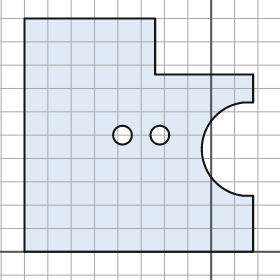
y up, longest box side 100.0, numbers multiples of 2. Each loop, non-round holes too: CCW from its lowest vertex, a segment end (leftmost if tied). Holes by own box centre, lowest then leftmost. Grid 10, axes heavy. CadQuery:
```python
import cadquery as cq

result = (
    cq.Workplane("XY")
    .moveTo(-80.0, 0.0)
    .lineTo(18.0, 0.0)
    .lineTo(18.0, 24.0)
    .lineTo(14.0, 24.0)
    .threePointArc((-4.0, 44.0), (14.0, 64.0))
    .lineTo(18.0, 64.0)
    .lineTo(18.0, 76.0)
    .lineTo(-24.0, 76.0)
    .lineTo(-24.0, 100.0)
    .lineTo(-80.0, 100.0)
    .close()
    .moveTo(-38.0, 50.0)
    .circle(4.0)
    .moveTo(-22.0, 50.0)
    .circle(4.0)
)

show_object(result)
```